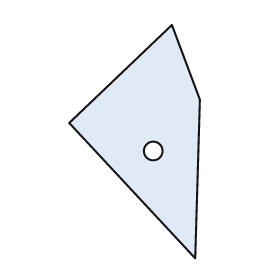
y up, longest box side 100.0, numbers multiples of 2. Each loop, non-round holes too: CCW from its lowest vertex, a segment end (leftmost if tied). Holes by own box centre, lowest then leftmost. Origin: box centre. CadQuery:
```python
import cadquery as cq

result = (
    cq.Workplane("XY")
    .moveTo(26.0, -50.0)
    .lineTo(28.0, 18.0)
    .lineTo(16.0, 50.0)
    .lineTo(-28.0, 8.0)
    .close()
    .moveTo(8.0, -4.0)
    .circle(4.0)
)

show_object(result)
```